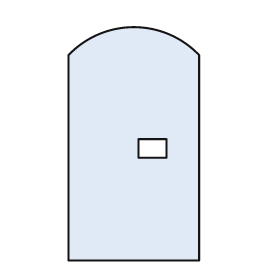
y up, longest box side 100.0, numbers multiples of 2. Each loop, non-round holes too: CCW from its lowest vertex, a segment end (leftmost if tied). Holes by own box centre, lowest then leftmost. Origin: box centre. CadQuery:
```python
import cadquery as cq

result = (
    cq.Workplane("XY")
    .moveTo(-28.0, -50.0)
    .lineTo(28.0, -50.0)
    .lineTo(28.0, 38.0)
    .threePointArc((0.0, 50.0), (-28.0, 38.0))
    .close()
    .moveTo(2.0, -6.0)
    .lineTo(14.0, -6.0)
    .lineTo(14.0, 2.0)
    .lineTo(2.0, 2.0)
    .close()
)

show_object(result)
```